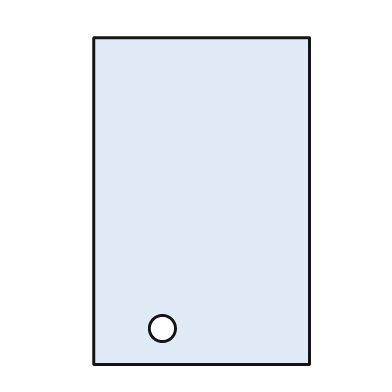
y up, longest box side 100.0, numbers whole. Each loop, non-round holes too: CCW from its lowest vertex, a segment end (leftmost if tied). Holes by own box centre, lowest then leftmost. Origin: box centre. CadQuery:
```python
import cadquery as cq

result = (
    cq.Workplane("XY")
    .moveTo(-33.0, -50.0)
    .lineTo(33.0, -50.0)
    .lineTo(33.0, 50.0)
    .lineTo(-33.0, 50.0)
    .close()
    .moveTo(-12.0, -39.0)
    .circle(4.0)
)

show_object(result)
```